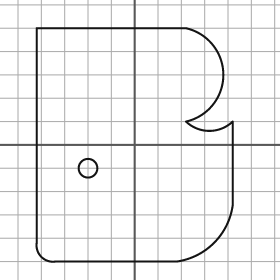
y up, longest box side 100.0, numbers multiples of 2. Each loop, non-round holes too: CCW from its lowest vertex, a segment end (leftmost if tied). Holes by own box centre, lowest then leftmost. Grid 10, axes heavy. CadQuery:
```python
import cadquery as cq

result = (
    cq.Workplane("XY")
    .moveTo(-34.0, -50.0)
    .lineTo(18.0, -50.0)
    .threePointArc((34.0, -42.0), (42.0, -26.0))
    .lineTo(42.0, 10.0)
    .threePointArc((32.0, 6.0), (22.0, 10.0))
    .threePointArc((38.0, 30.0), (22.0, 50.0))
    .lineTo(-42.0, 50.0)
    .lineTo(-42.0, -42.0)
    .threePointArc((-40.0, -48.0), (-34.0, -50.0))
    .close()
    .moveTo(-20.0, -10.0)
    .circle(4.0)
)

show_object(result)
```